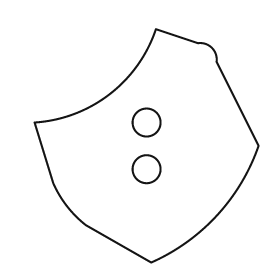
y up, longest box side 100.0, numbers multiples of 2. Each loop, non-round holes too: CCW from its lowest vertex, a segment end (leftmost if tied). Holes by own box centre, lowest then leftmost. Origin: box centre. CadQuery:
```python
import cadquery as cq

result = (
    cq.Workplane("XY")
    .moveTo(2.0, -50.0)
    .threePointArc((30.0, -30.0), (48.0, 0.0))
    .lineTo(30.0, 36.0)
    .threePointArc((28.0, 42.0), (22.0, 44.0))
    .lineTo(4.0, 50.0)
    .threePointArc((-16.0, 22.0), (-48.0, 10.0))
    .lineTo(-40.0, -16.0)
    .threePointArc((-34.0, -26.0), (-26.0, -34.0))
    .close()
    .moveTo(0.0, -10.0)
    .circle(6.0)
    .moveTo(0.0, 10.0)
    .circle(6.0)
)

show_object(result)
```